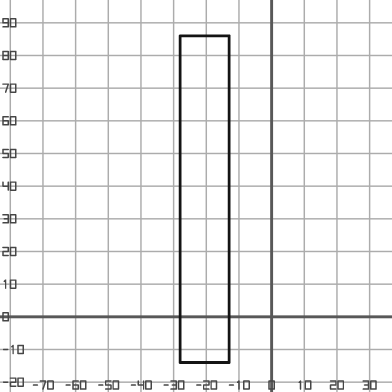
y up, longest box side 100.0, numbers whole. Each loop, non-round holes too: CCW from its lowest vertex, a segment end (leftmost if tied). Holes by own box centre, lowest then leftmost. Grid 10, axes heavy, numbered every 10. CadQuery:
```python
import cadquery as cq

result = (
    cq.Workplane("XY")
    .moveTo(-28.0, -14.0)
    .lineTo(-13.0, -14.0)
    .lineTo(-13.0, 86.0)
    .lineTo(-28.0, 86.0)
    .close()
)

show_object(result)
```